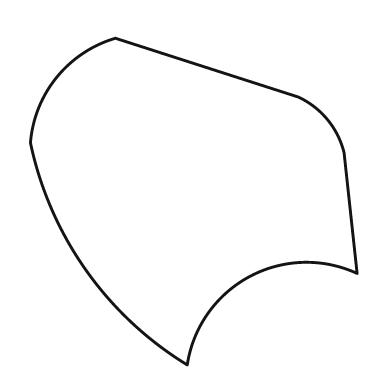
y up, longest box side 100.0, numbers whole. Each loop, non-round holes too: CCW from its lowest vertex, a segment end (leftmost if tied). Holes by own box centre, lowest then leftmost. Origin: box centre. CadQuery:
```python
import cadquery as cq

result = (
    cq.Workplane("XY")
    .moveTo(-2.0, -50.0)
    .threePointArc((17.0, -23.0), (50.0, -22.0))
    .lineTo(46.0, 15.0)
    .threePointArc((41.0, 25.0), (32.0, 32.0))
    .lineTo(-24.0, 50.0)
    .threePointArc((-42.0, 38.0), (-50.0, 18.0))
    .threePointArc((-33.0, -21.0), (-2.0, -50.0))
    .close()
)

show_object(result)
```